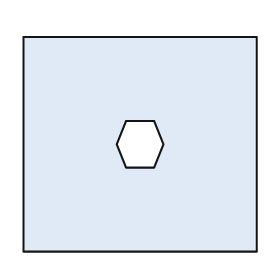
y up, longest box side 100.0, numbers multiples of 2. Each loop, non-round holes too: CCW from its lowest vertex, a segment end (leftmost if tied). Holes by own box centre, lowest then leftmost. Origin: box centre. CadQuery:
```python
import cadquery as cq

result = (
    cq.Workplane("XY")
    .moveTo(-50.0, -46.0)
    .lineTo(50.0, -46.0)
    .lineTo(50.0, 46.0)
    .lineTo(-50.0, 46.0)
    .close()
    .moveTo(-6.0, -10.0)
    .lineTo(6.0, -10.0)
    .lineTo(10.0, 0.0)
    .lineTo(6.0, 10.0)
    .lineTo(-6.0, 10.0)
    .lineTo(-10.0, 0.0)
    .close()
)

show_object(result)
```